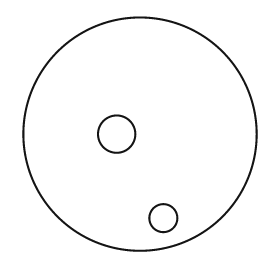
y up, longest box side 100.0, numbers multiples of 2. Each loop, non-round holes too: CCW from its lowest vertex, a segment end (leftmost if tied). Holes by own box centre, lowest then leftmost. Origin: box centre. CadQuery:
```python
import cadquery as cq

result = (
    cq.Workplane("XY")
    .moveTo(0.0, 0.0)
    .circle(50.0)
    .moveTo(10.0, -36.0)
    .circle(6.0)
    .moveTo(-10.0, 0.0)
    .circle(8.0)
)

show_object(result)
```